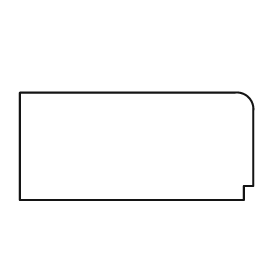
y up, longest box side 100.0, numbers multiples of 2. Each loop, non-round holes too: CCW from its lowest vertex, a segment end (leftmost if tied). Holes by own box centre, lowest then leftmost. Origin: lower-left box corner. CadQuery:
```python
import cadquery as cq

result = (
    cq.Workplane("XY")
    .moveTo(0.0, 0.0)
    .lineTo(96.0, 0.0)
    .lineTo(96.0, 6.0)
    .lineTo(100.0, 6.0)
    .lineTo(100.0, 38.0)
    .threePointArc((98.0, 44.0), (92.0, 46.0))
    .lineTo(0.0, 46.0)
    .close()
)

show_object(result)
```